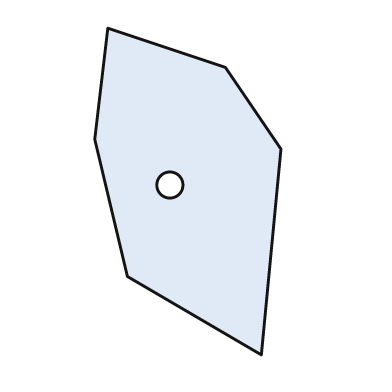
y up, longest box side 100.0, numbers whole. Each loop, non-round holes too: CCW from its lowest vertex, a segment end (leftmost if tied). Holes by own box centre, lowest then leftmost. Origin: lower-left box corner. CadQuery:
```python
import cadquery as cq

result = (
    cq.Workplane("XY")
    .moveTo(51.0, 0.0)
    .lineTo(57.0, 63.0)
    .lineTo(40.0, 88.0)
    .lineTo(4.0, 100.0)
    .lineTo(0.0, 66.0)
    .lineTo(10.0, 24.0)
    .close()
    .moveTo(23.0, 52.0)
    .circle(4.0)
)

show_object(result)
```